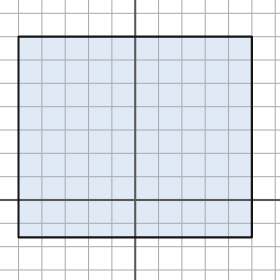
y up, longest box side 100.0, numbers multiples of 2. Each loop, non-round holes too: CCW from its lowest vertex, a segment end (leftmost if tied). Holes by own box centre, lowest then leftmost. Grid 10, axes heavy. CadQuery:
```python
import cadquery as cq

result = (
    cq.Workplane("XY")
    .moveTo(-50.0, -16.0)
    .lineTo(50.0, -16.0)
    .lineTo(50.0, 70.0)
    .lineTo(-50.0, 70.0)
    .close()
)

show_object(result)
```